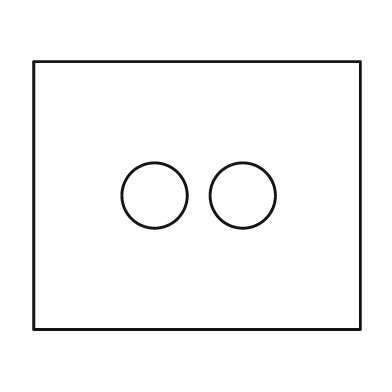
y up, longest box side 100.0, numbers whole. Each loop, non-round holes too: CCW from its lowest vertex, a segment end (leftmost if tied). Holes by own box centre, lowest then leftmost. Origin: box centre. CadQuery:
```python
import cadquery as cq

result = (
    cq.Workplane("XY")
    .moveTo(-50.0, -41.0)
    .lineTo(50.0, -41.0)
    .lineTo(50.0, 41.0)
    .lineTo(-50.0, 41.0)
    .close()
    .moveTo(-13.0, 0.0)
    .circle(10.0)
    .moveTo(14.0, 0.0)
    .circle(10.0)
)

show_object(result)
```